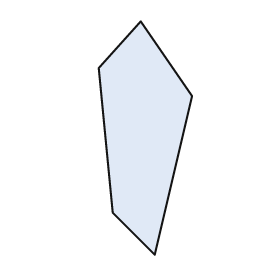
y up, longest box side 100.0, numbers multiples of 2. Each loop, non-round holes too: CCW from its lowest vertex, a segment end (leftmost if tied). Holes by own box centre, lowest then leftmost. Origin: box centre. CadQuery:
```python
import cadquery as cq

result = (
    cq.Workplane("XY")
    .moveTo(4.0, -50.0)
    .lineTo(20.0, 18.0)
    .lineTo(-2.0, 50.0)
    .lineTo(-20.0, 30.0)
    .lineTo(-14.0, -32.0)
    .close()
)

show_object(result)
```